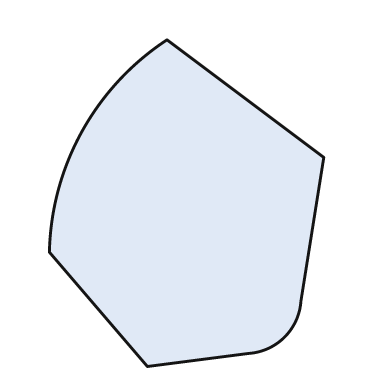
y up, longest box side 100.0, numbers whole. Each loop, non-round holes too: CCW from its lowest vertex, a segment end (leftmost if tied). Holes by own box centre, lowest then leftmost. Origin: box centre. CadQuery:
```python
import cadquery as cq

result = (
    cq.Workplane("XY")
    .moveTo(-12.0, -50.0)
    .lineTo(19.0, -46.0)
    .threePointArc((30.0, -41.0), (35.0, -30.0))
    .lineTo(42.0, 14.0)
    .lineTo(-6.0, 50.0)
    .threePointArc((-32.0, 22.0), (-42.0, -15.0))
    .close()
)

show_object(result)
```